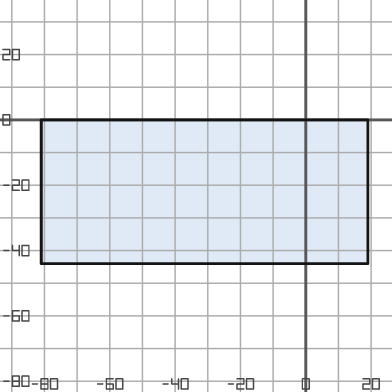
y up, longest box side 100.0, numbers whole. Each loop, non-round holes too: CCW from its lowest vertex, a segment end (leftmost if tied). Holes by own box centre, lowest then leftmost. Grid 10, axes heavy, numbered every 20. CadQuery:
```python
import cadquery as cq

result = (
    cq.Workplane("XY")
    .moveTo(-81.0, -44.0)
    .lineTo(19.0, -44.0)
    .lineTo(19.0, 0.0)
    .lineTo(-81.0, 0.0)
    .close()
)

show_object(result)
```